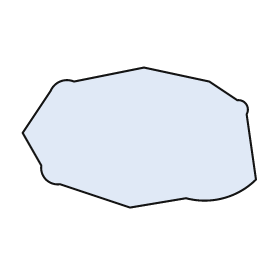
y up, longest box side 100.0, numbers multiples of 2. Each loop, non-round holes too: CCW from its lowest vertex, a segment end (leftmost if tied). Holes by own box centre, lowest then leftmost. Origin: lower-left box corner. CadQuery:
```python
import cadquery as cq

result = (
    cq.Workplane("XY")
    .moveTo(46.0, 0.0)
    .lineTo(70.0, 4.0)
    .threePointArc((86.0, 4.0), (100.0, 12.0))
    .lineTo(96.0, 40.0)
    .threePointArc((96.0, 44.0), (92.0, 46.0))
    .lineTo(80.0, 54.0)
    .lineTo(52.0, 60.0)
    .lineTo(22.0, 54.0)
    .threePointArc((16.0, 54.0), (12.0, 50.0))
    .lineTo(0.0, 32.0)
    .lineTo(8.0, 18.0)
    .threePointArc((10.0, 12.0), (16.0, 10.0))
    .close()
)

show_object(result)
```